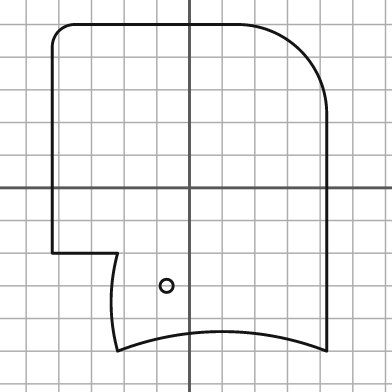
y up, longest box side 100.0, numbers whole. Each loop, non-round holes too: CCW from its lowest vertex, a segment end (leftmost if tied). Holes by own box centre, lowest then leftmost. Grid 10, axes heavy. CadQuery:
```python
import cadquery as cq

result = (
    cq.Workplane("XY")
    .moveTo(-22.0, -50.0)
    .threePointArc((10.0, -44.0), (42.0, -50.0))
    .lineTo(42.0, 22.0)
    .threePointArc((34.0, 42.0), (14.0, 50.0))
    .lineTo(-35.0, 50.0)
    .threePointArc((-40.0, 48.0), (-42.0, 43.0))
    .lineTo(-42.0, -20.0)
    .lineTo(-22.0, -20.0)
    .threePointArc((-24.0, -35.0), (-22.0, -50.0))
    .close()
    .moveTo(-7.0, -30.0)
    .circle(2.0)
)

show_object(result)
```